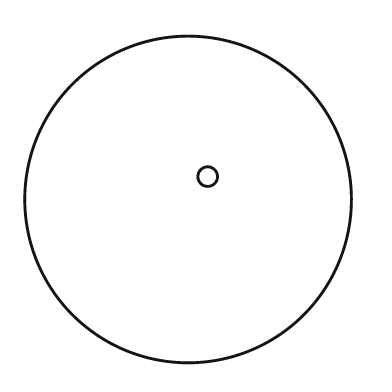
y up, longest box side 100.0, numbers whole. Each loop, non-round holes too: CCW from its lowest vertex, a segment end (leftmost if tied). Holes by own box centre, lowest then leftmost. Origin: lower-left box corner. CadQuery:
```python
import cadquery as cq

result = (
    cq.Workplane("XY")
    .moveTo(50.0, 50.0)
    .circle(50.0)
    .moveTo(56.0, 57.0)
    .circle(3.0)
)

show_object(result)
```